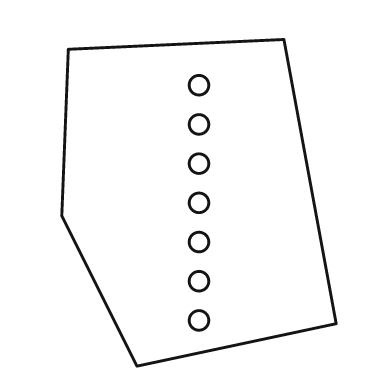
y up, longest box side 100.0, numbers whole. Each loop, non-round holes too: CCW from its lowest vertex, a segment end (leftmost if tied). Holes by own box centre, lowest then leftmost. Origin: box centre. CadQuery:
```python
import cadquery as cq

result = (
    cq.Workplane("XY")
    .moveTo(-19.0, -50.0)
    .lineTo(42.0, -37.0)
    .lineTo(26.0, 50.0)
    .lineTo(-40.0, 47.0)
    .lineTo(-42.0, -4.0)
    .close()
    .moveTo(0.0, -36.0)
    .circle(3.0)
    .moveTo(0.0, -24.0)
    .circle(3.0)
    .moveTo(0.0, -12.0)
    .circle(3.0)
    .moveTo(0.0, 0.0)
    .circle(3.0)
    .moveTo(0.0, 12.0)
    .circle(3.0)
    .moveTo(0.0, 24.0)
    .circle(3.0)
    .moveTo(0.0, 36.0)
    .circle(3.0)
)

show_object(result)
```